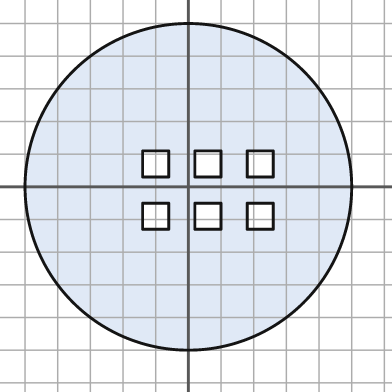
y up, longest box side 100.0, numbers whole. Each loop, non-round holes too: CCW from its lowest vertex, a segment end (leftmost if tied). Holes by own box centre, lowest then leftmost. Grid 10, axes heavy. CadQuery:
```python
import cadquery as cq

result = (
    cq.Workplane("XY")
    .moveTo(0.0, 0.0)
    .circle(50.0)
    .moveTo(-14.0, -13.0)
    .lineTo(-6.0, -13.0)
    .lineTo(-6.0, -5.0)
    .lineTo(-14.0, -5.0)
    .close()
    .moveTo(2.0, -13.0)
    .lineTo(10.0, -13.0)
    .lineTo(10.0, -5.0)
    .lineTo(2.0, -5.0)
    .close()
    .moveTo(18.0, -13.0)
    .lineTo(26.0, -13.0)
    .lineTo(26.0, -5.0)
    .lineTo(18.0, -5.0)
    .close()
    .moveTo(-14.0, 3.0)
    .lineTo(-6.0, 3.0)
    .lineTo(-6.0, 11.0)
    .lineTo(-14.0, 11.0)
    .close()
    .moveTo(2.0, 3.0)
    .lineTo(10.0, 3.0)
    .lineTo(10.0, 11.0)
    .lineTo(2.0, 11.0)
    .close()
    .moveTo(18.0, 3.0)
    .lineTo(26.0, 3.0)
    .lineTo(26.0, 11.0)
    .lineTo(18.0, 11.0)
    .close()
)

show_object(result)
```